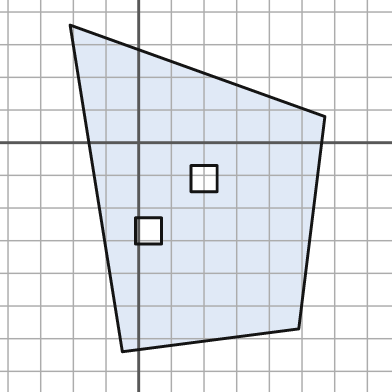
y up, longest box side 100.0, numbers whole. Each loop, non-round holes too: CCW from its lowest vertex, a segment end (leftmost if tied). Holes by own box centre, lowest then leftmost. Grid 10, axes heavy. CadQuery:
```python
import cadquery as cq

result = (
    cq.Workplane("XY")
    .moveTo(-5.0, -64.0)
    .lineTo(49.0, -57.0)
    .lineTo(57.0, 8.0)
    .lineTo(-21.0, 36.0)
    .close()
    .moveTo(-1.0, -31.0)
    .lineTo(7.0, -31.0)
    .lineTo(7.0, -23.0)
    .lineTo(-1.0, -23.0)
    .close()
    .moveTo(16.0, -15.0)
    .lineTo(24.0, -15.0)
    .lineTo(24.0, -7.0)
    .lineTo(16.0, -7.0)
    .close()
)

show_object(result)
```